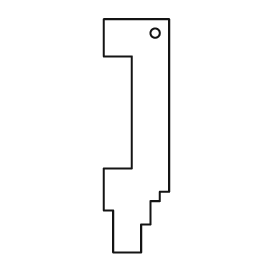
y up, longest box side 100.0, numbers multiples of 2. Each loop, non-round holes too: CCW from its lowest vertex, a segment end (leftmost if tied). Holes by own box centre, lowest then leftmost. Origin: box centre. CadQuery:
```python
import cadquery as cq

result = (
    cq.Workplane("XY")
    .moveTo(-10.0, -50.0)
    .lineTo(2.0, -50.0)
    .lineTo(2.0, -38.0)
    .lineTo(6.0, -38.0)
    .lineTo(6.0, -28.0)
    .lineTo(10.0, -28.0)
    .lineTo(10.0, -24.0)
    .lineTo(14.0, -24.0)
    .lineTo(14.0, 50.0)
    .lineTo(-14.0, 50.0)
    .lineTo(-14.0, 34.0)
    .lineTo(-2.0, 34.0)
    .lineTo(-2.0, -14.0)
    .lineTo(-14.0, -14.0)
    .lineTo(-14.0, -32.0)
    .lineTo(-10.0, -32.0)
    .close()
    .moveTo(8.0, 44.0)
    .circle(2.0)
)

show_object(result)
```